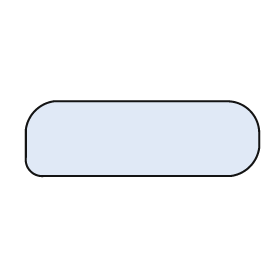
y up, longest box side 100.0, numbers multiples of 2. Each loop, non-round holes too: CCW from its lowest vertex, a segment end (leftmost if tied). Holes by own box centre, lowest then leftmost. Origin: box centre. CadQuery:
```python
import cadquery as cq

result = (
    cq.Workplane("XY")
    .moveTo(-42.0, -16.0)
    .lineTo(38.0, -16.0)
    .threePointArc((46.0, -12.0), (50.0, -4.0))
    .lineTo(50.0, 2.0)
    .threePointArc((46.0, 12.0), (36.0, 16.0))
    .lineTo(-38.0, 16.0)
    .threePointArc((-46.0, 12.0), (-50.0, 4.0))
    .lineTo(-50.0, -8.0)
    .threePointArc((-48.0, -14.0), (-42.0, -16.0))
    .close()
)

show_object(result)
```